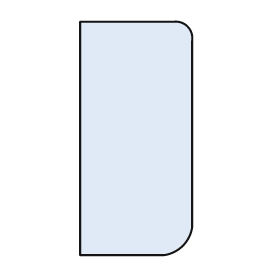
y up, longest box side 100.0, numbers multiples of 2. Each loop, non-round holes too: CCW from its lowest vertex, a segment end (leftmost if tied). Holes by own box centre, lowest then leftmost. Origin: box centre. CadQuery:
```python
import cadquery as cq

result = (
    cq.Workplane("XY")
    .moveTo(-24.0, -50.0)
    .lineTo(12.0, -50.0)
    .threePointArc((20.0, -46.0), (24.0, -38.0))
    .lineTo(24.0, 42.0)
    .threePointArc((22.0, 48.0), (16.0, 50.0))
    .lineTo(-24.0, 50.0)
    .close()
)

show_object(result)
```